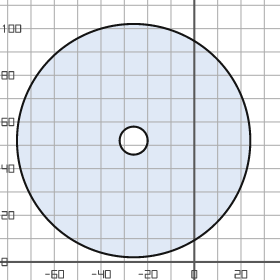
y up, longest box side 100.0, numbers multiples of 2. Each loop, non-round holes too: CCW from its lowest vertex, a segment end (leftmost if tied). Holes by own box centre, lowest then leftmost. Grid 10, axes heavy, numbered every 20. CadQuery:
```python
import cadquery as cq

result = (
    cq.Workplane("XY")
    .moveTo(-26.0, 52.0)
    .circle(50.0)
    .moveTo(-26.0, 52.0)
    .circle(6.0)
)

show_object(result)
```